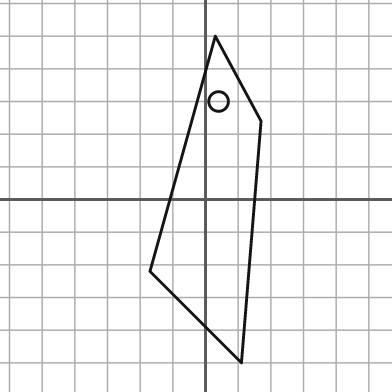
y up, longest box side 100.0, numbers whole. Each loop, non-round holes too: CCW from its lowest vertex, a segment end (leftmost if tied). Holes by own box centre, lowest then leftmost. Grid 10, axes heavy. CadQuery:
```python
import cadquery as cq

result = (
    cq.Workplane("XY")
    .moveTo(11.0, -50.0)
    .lineTo(17.0, 24.0)
    .lineTo(3.0, 50.0)
    .lineTo(-17.0, -22.0)
    .close()
    .moveTo(4.0, 30.0)
    .circle(3.0)
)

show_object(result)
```